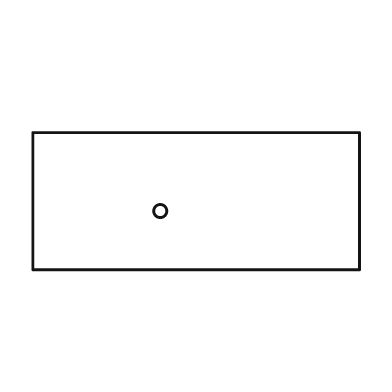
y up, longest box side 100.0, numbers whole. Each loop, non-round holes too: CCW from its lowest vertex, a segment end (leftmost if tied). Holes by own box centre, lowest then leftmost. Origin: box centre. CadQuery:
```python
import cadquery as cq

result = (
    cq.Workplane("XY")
    .moveTo(-50.0, -21.0)
    .lineTo(50.0, -21.0)
    .lineTo(50.0, 21.0)
    .lineTo(-50.0, 21.0)
    .close()
    .moveTo(-11.0, -3.0)
    .circle(2.0)
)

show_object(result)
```